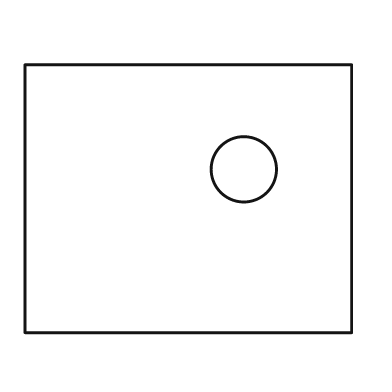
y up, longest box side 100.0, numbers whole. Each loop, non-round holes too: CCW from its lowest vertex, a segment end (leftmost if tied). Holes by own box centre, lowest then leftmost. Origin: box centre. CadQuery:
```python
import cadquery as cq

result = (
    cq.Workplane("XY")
    .moveTo(-50.0, -41.0)
    .lineTo(50.0, -41.0)
    .lineTo(50.0, 41.0)
    .lineTo(-50.0, 41.0)
    .close()
    .moveTo(17.0, 9.0)
    .circle(10.0)
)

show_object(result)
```